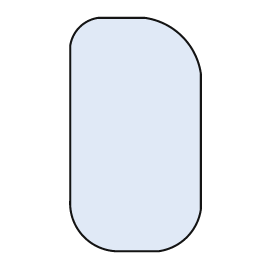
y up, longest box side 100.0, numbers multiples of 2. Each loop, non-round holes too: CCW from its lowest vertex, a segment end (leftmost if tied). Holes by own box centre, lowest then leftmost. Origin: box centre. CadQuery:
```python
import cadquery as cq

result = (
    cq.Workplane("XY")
    .moveTo(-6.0, -50.0)
    .lineTo(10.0, -50.0)
    .threePointArc((22.0, -44.0), (28.0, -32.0))
    .lineTo(28.0, 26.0)
    .threePointArc((20.0, 42.0), (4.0, 50.0))
    .lineTo(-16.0, 50.0)
    .threePointArc((-24.0, 46.0), (-28.0, 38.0))
    .lineTo(-28.0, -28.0)
    .threePointArc((-22.0, -44.0), (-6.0, -50.0))
    .close()
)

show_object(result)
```